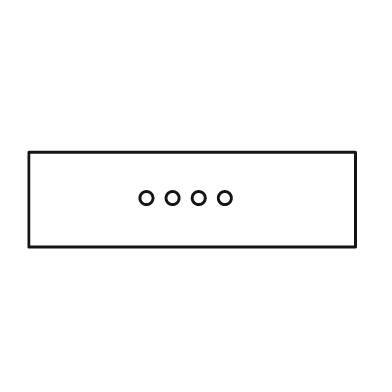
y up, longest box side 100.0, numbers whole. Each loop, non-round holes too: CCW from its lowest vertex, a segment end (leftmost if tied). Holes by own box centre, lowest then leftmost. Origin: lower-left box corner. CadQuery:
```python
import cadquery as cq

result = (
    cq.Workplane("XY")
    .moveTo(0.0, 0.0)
    .lineTo(100.0, 0.0)
    .lineTo(100.0, 29.0)
    .lineTo(0.0, 29.0)
    .close()
    .moveTo(36.0, 15.0)
    .circle(2.0)
    .moveTo(44.0, 15.0)
    .circle(2.0)
    .moveTo(52.0, 15.0)
    .circle(2.0)
    .moveTo(60.0, 15.0)
    .circle(2.0)
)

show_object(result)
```